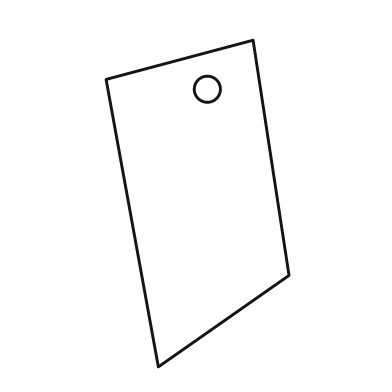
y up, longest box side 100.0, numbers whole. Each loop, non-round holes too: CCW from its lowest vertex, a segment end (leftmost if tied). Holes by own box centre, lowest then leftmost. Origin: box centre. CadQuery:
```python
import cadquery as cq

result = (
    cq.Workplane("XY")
    .moveTo(-12.0, -50.0)
    .lineTo(28.0, -22.0)
    .lineTo(17.0, 50.0)
    .lineTo(-28.0, 38.0)
    .close()
    .moveTo(3.0, 35.0)
    .circle(4.0)
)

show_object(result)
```